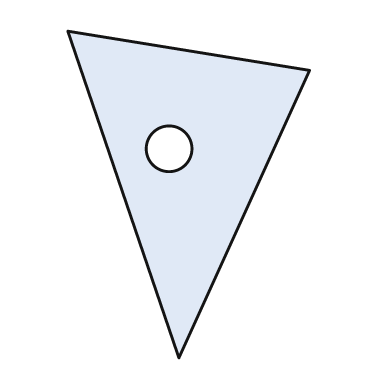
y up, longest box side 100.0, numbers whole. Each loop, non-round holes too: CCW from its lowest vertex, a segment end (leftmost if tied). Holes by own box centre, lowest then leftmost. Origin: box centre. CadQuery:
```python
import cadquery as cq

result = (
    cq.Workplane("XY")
    .moveTo(-3.0, -50.0)
    .lineTo(37.0, 38.0)
    .lineTo(-37.0, 50.0)
    .close()
    .moveTo(-6.0, 14.0)
    .circle(7.0)
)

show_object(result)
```